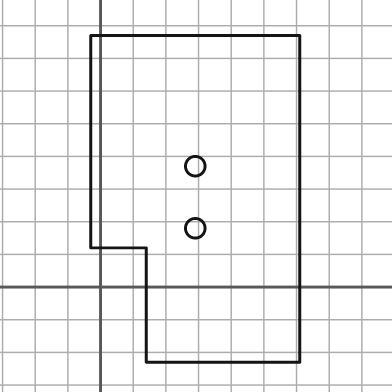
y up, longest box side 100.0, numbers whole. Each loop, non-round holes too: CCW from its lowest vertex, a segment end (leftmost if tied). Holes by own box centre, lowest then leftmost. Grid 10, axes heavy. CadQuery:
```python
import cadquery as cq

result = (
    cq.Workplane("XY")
    .moveTo(14.0, -23.0)
    .lineTo(61.0, -23.0)
    .lineTo(61.0, 77.0)
    .lineTo(-3.0, 77.0)
    .lineTo(-3.0, 12.0)
    .lineTo(14.0, 12.0)
    .close()
    .moveTo(29.0, 18.0)
    .circle(3.0)
    .moveTo(29.0, 37.0)
    .circle(3.0)
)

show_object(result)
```